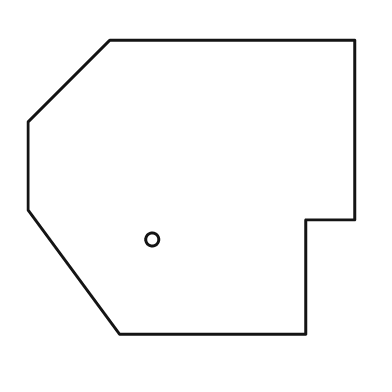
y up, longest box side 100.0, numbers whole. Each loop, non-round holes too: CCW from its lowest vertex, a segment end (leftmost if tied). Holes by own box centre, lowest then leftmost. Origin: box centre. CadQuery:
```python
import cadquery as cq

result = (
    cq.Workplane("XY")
    .moveTo(-22.0, -45.0)
    .lineTo(35.0, -45.0)
    .lineTo(35.0, -10.0)
    .lineTo(50.0, -10.0)
    .lineTo(50.0, 45.0)
    .lineTo(-25.0, 45.0)
    .lineTo(-50.0, 20.0)
    .lineTo(-50.0, -7.0)
    .close()
    .moveTo(-12.0, -16.0)
    .circle(2.0)
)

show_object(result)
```